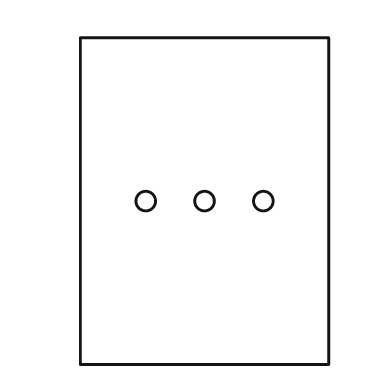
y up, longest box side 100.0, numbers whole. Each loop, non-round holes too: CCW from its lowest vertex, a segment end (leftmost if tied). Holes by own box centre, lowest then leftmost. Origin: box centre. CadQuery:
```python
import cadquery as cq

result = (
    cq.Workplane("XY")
    .moveTo(-38.0, -50.0)
    .lineTo(38.0, -50.0)
    .lineTo(38.0, 50.0)
    .lineTo(-38.0, 50.0)
    .close()
    .moveTo(-18.0, 0.0)
    .circle(3.0)
    .moveTo(0.0, 0.0)
    .circle(3.0)
    .moveTo(18.0, 0.0)
    .circle(3.0)
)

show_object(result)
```